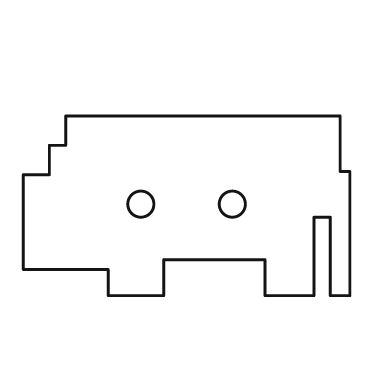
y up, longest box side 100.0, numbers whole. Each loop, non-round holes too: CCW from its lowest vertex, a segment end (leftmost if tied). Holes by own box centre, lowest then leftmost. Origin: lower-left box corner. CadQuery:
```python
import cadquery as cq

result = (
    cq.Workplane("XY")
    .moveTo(26.0, 0.0)
    .lineTo(43.0, 0.0)
    .lineTo(43.0, 11.0)
    .lineTo(74.0, 11.0)
    .lineTo(74.0, 0.0)
    .lineTo(89.0, 0.0)
    .lineTo(89.0, 24.0)
    .lineTo(94.0, 24.0)
    .lineTo(94.0, 0.0)
    .lineTo(100.0, 0.0)
    .lineTo(100.0, 38.0)
    .lineTo(97.0, 38.0)
    .lineTo(97.0, 55.0)
    .lineTo(13.0, 55.0)
    .lineTo(13.0, 46.0)
    .lineTo(8.0, 46.0)
    .lineTo(8.0, 37.0)
    .lineTo(0.0, 37.0)
    .lineTo(0.0, 8.0)
    .lineTo(26.0, 8.0)
    .close()
    .moveTo(36.0, 28.0)
    .circle(4.0)
    .moveTo(64.0, 28.0)
    .circle(4.0)
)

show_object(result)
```